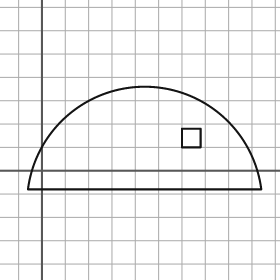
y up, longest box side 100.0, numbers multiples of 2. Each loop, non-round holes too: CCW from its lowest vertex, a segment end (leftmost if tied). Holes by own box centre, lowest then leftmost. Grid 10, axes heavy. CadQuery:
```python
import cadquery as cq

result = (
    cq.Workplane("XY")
    .moveTo(-6.0, -8.0)
    .lineTo(94.0, -8.0)
    .threePointArc((44.0, 36.0), (-6.0, -8.0))
    .close()
    .moveTo(60.0, 10.0)
    .lineTo(68.0, 10.0)
    .lineTo(68.0, 18.0)
    .lineTo(60.0, 18.0)
    .close()
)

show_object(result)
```